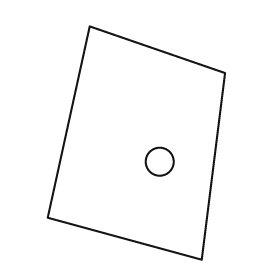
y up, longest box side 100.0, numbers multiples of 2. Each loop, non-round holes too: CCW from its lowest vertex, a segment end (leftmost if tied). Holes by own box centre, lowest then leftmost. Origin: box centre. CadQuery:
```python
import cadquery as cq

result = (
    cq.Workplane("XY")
    .moveTo(28.0, -50.0)
    .lineTo(38.0, 30.0)
    .lineTo(-20.0, 50.0)
    .lineTo(-38.0, -32.0)
    .close()
    .moveTo(10.0, -8.0)
    .circle(6.0)
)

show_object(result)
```